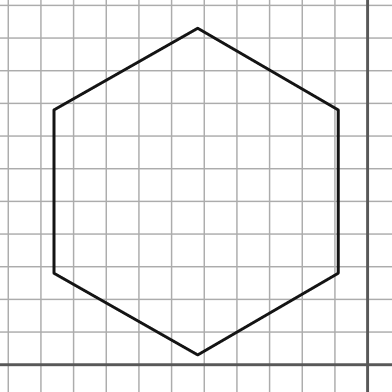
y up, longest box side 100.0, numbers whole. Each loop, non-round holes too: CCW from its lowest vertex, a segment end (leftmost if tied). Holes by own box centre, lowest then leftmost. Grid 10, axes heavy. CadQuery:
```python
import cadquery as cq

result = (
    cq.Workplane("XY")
    .moveTo(-52.0, 3.0)
    .lineTo(-9.0, 28.0)
    .lineTo(-9.0, 78.0)
    .lineTo(-52.0, 103.0)
    .lineTo(-96.0, 78.0)
    .lineTo(-96.0, 28.0)
    .close()
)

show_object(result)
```